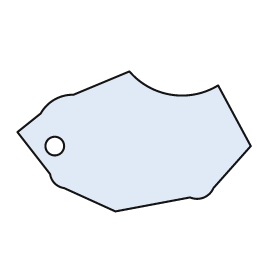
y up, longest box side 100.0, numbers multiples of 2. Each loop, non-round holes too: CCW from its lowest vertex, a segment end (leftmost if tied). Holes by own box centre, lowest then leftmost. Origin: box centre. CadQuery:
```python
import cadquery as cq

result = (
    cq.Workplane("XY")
    .moveTo(-8.0, -30.0)
    .lineTo(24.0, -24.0)
    .threePointArc((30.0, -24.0), (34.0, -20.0))
    .lineTo(50.0, -2.0)
    .lineTo(36.0, 24.0)
    .threePointArc((16.0, 20.0), (-2.0, 30.0))
    .lineTo(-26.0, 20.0)
    .threePointArc((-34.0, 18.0), (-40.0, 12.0))
    .lineTo(-50.0, 4.0)
    .lineTo(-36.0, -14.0)
    .threePointArc((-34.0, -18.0), (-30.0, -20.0))
    .close()
    .moveTo(-34.0, -2.0)
    .circle(4.0)
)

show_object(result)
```